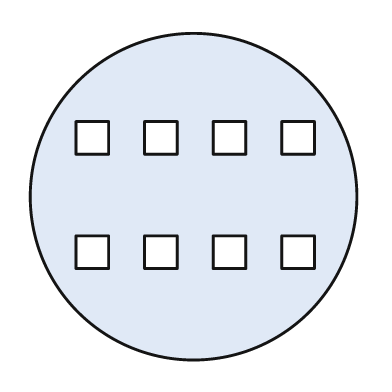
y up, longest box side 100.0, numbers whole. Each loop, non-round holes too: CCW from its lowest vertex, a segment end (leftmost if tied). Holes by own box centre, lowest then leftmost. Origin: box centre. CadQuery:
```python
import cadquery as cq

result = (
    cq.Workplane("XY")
    .moveTo(0.0, 0.0)
    .circle(50.0)
    .moveTo(-36.0, -22.0)
    .lineTo(-26.0, -22.0)
    .lineTo(-26.0, -12.0)
    .lineTo(-36.0, -12.0)
    .close()
    .moveTo(-15.0, -22.0)
    .lineTo(-5.0, -22.0)
    .lineTo(-5.0, -12.0)
    .lineTo(-15.0, -12.0)
    .close()
    .moveTo(6.0, -22.0)
    .lineTo(16.0, -22.0)
    .lineTo(16.0, -12.0)
    .lineTo(6.0, -12.0)
    .close()
    .moveTo(27.0, -22.0)
    .lineTo(37.0, -22.0)
    .lineTo(37.0, -12.0)
    .lineTo(27.0, -12.0)
    .close()
    .moveTo(-36.0, 13.0)
    .lineTo(-26.0, 13.0)
    .lineTo(-26.0, 23.0)
    .lineTo(-36.0, 23.0)
    .close()
    .moveTo(-15.0, 13.0)
    .lineTo(-5.0, 13.0)
    .lineTo(-5.0, 23.0)
    .lineTo(-15.0, 23.0)
    .close()
    .moveTo(6.0, 13.0)
    .lineTo(16.0, 13.0)
    .lineTo(16.0, 23.0)
    .lineTo(6.0, 23.0)
    .close()
    .moveTo(27.0, 13.0)
    .lineTo(37.0, 13.0)
    .lineTo(37.0, 23.0)
    .lineTo(27.0, 23.0)
    .close()
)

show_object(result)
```